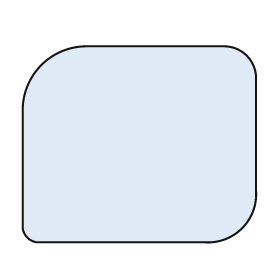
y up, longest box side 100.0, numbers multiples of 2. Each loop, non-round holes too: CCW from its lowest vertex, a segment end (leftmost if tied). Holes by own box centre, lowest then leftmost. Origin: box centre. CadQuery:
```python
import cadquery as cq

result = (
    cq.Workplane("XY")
    .moveTo(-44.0, -42.0)
    .lineTo(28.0, -42.0)
    .threePointArc((44.0, -36.0), (50.0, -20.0))
    .lineTo(50.0, 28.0)
    .threePointArc((46.0, 38.0), (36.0, 42.0))
    .lineTo(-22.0, 42.0)
    .threePointArc((-42.0, 34.0), (-50.0, 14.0))
    .lineTo(-50.0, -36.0)
    .threePointArc((-48.0, -40.0), (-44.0, -42.0))
    .close()
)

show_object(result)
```